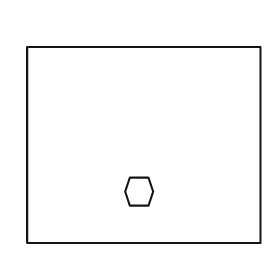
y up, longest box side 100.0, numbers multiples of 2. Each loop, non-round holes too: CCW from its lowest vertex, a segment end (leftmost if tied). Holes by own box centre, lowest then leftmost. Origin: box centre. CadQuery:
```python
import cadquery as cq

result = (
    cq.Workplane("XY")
    .moveTo(-50.0, -42.0)
    .lineTo(50.0, -42.0)
    .lineTo(50.0, 42.0)
    .lineTo(-50.0, 42.0)
    .close()
    .moveTo(-6.0, -26.0)
    .lineTo(2.0, -26.0)
    .lineTo(4.0, -20.0)
    .lineTo(2.0, -14.0)
    .lineTo(-6.0, -14.0)
    .lineTo(-8.0, -20.0)
    .close()
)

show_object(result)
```